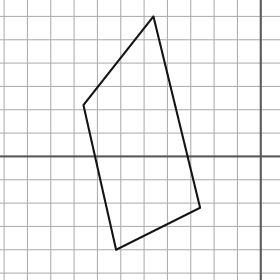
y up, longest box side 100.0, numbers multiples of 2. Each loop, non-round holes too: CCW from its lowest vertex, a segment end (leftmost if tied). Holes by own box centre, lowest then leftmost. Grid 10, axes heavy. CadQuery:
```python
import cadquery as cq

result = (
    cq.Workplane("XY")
    .moveTo(-62.0, -40.0)
    .lineTo(-26.0, -22.0)
    .lineTo(-46.0, 60.0)
    .lineTo(-76.0, 22.0)
    .close()
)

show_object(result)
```